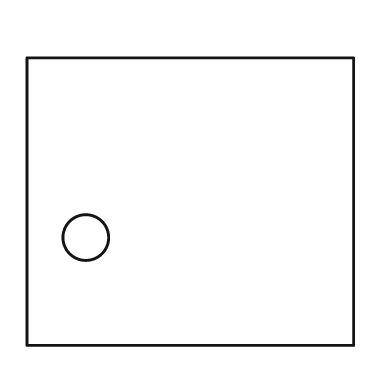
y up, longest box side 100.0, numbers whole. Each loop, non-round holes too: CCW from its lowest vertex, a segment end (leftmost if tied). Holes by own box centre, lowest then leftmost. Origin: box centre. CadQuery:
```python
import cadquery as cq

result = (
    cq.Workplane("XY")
    .moveTo(-50.0, -44.0)
    .lineTo(50.0, -44.0)
    .lineTo(50.0, 44.0)
    .lineTo(-50.0, 44.0)
    .close()
    .moveTo(-32.0, -11.0)
    .circle(7.0)
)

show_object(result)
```